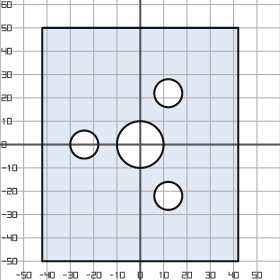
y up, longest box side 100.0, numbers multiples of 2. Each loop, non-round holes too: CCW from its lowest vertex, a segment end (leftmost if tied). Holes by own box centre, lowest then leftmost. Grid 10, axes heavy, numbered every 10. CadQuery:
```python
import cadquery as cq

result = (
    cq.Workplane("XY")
    .moveTo(-42.0, -50.0)
    .lineTo(42.0, -50.0)
    .lineTo(42.0, 50.0)
    .lineTo(-42.0, 50.0)
    .close()
    .moveTo(12.0, -22.0)
    .circle(6.0)
    .moveTo(-24.0, 0.0)
    .circle(6.0)
    .moveTo(0.0, 0.0)
    .circle(10.0)
    .moveTo(12.0, 22.0)
    .circle(6.0)
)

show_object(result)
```